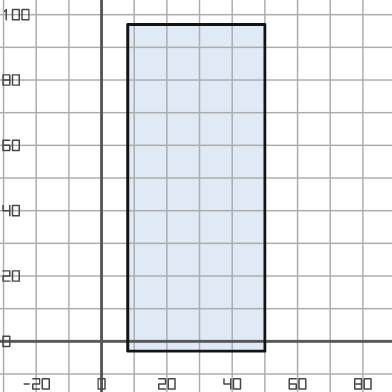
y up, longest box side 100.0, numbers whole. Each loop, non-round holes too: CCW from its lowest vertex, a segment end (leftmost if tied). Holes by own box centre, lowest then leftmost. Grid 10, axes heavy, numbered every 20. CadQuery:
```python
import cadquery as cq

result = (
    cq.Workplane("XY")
    .moveTo(8.0, -3.0)
    .lineTo(50.0, -3.0)
    .lineTo(50.0, 97.0)
    .lineTo(8.0, 97.0)
    .close()
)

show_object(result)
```